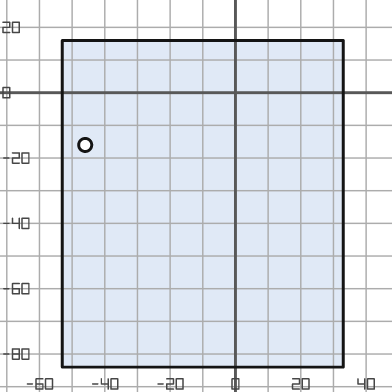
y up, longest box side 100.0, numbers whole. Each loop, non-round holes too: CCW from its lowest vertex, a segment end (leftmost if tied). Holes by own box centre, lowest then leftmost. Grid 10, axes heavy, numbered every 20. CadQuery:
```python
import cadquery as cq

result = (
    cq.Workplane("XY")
    .moveTo(-53.0, -84.0)
    .lineTo(33.0, -84.0)
    .lineTo(33.0, 16.0)
    .lineTo(-53.0, 16.0)
    .close()
    .moveTo(-46.0, -16.0)
    .circle(2.0)
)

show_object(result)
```